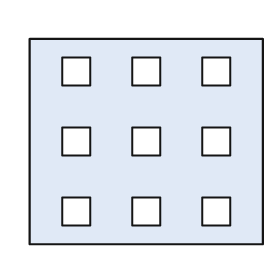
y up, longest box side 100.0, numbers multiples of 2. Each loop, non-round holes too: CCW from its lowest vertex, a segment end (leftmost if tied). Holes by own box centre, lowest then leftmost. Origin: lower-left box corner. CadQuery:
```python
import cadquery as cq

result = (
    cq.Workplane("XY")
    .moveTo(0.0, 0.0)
    .lineTo(100.0, 0.0)
    .lineTo(100.0, 88.0)
    .lineTo(0.0, 88.0)
    .close()
    .moveTo(14.0, 8.0)
    .lineTo(26.0, 8.0)
    .lineTo(26.0, 20.0)
    .lineTo(14.0, 20.0)
    .close()
    .moveTo(44.0, 8.0)
    .lineTo(56.0, 8.0)
    .lineTo(56.0, 20.0)
    .lineTo(44.0, 20.0)
    .close()
    .moveTo(74.0, 8.0)
    .lineTo(86.0, 8.0)
    .lineTo(86.0, 20.0)
    .lineTo(74.0, 20.0)
    .close()
    .moveTo(14.0, 38.0)
    .lineTo(26.0, 38.0)
    .lineTo(26.0, 50.0)
    .lineTo(14.0, 50.0)
    .close()
    .moveTo(44.0, 38.0)
    .lineTo(56.0, 38.0)
    .lineTo(56.0, 50.0)
    .lineTo(44.0, 50.0)
    .close()
    .moveTo(74.0, 38.0)
    .lineTo(86.0, 38.0)
    .lineTo(86.0, 50.0)
    .lineTo(74.0, 50.0)
    .close()
    .moveTo(14.0, 68.0)
    .lineTo(26.0, 68.0)
    .lineTo(26.0, 80.0)
    .lineTo(14.0, 80.0)
    .close()
    .moveTo(44.0, 68.0)
    .lineTo(56.0, 68.0)
    .lineTo(56.0, 80.0)
    .lineTo(44.0, 80.0)
    .close()
    .moveTo(74.0, 68.0)
    .lineTo(86.0, 68.0)
    .lineTo(86.0, 80.0)
    .lineTo(74.0, 80.0)
    .close()
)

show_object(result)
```